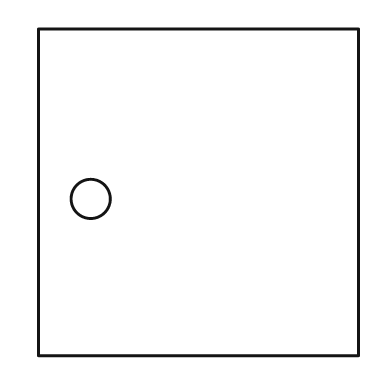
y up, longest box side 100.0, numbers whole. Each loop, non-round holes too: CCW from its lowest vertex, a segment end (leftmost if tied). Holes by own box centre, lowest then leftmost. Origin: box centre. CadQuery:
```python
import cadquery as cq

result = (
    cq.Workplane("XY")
    .moveTo(-49.0, -50.0)
    .lineTo(49.0, -50.0)
    .lineTo(49.0, 50.0)
    .lineTo(-49.0, 50.0)
    .close()
    .moveTo(-33.0, -2.0)
    .circle(6.0)
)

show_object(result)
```